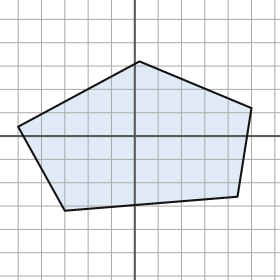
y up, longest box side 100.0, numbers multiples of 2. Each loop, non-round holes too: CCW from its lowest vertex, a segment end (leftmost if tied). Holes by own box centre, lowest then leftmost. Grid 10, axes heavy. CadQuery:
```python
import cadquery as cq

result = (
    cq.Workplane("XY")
    .moveTo(-30.0, -32.0)
    .lineTo(44.0, -26.0)
    .lineTo(50.0, 12.0)
    .lineTo(2.0, 32.0)
    .lineTo(-50.0, 4.0)
    .close()
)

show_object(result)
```